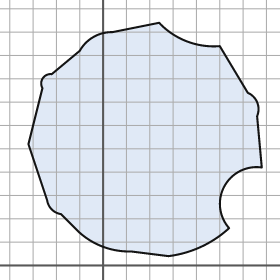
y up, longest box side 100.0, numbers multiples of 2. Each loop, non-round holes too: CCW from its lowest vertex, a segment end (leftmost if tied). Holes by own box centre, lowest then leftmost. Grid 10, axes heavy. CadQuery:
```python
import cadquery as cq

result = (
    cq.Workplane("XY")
    .moveTo(28.0, 4.0)
    .threePointArc((42.0, 8.0), (54.0, 16.0))
    .threePointArc((52.0, 34.0), (68.0, 42.0))
    .lineTo(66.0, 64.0)
    .threePointArc((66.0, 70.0), (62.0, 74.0))
    .lineTo(50.0, 94.0)
    .threePointArc((36.0, 96.0), (24.0, 104.0))
    .lineTo(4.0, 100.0)
    .threePointArc((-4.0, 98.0), (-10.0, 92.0))
    .lineTo(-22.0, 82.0)
    .threePointArc((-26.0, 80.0), (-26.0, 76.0))
    .lineTo(-32.0, 52.0)
    .lineTo(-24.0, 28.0)
    .threePointArc((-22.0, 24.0), (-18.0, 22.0))
    .lineTo(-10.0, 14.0)
    .threePointArc((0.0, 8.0), (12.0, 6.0))
    .close()
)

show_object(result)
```